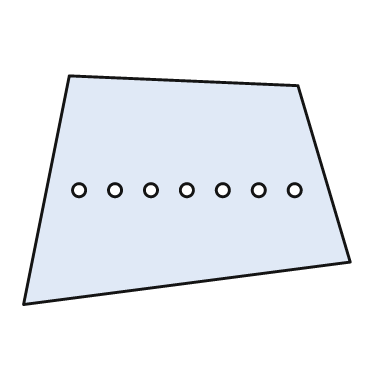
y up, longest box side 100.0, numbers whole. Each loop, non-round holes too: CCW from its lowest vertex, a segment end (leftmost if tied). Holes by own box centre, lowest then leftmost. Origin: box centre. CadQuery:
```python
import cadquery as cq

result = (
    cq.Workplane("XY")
    .moveTo(-50.0, -35.0)
    .lineTo(50.0, -22.0)
    .lineTo(34.0, 32.0)
    .lineTo(-36.0, 35.0)
    .close()
    .moveTo(-33.0, 0.0)
    .circle(2.0)
    .moveTo(-22.0, 0.0)
    .circle(2.0)
    .moveTo(-11.0, 0.0)
    .circle(2.0)
    .moveTo(0.0, 0.0)
    .circle(2.0)
    .moveTo(11.0, 0.0)
    .circle(2.0)
    .moveTo(22.0, 0.0)
    .circle(2.0)
    .moveTo(33.0, 0.0)
    .circle(2.0)
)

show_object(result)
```